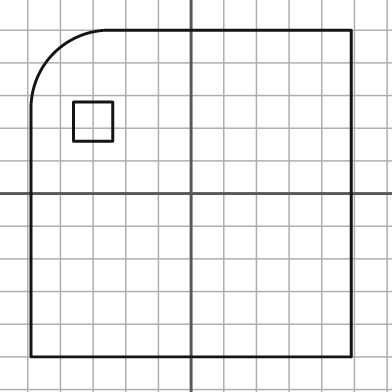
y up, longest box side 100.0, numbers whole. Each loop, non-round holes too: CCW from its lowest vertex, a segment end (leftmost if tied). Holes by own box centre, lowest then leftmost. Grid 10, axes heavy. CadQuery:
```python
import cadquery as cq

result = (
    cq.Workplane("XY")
    .moveTo(-49.0, -50.0)
    .lineTo(49.0, -50.0)
    .lineTo(49.0, 50.0)
    .lineTo(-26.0, 50.0)
    .threePointArc((-42.0, 43.0), (-49.0, 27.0))
    .close()
    .moveTo(-36.0, 16.0)
    .lineTo(-24.0, 16.0)
    .lineTo(-24.0, 28.0)
    .lineTo(-36.0, 28.0)
    .close()
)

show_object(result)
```